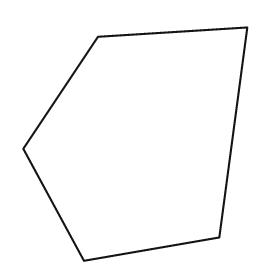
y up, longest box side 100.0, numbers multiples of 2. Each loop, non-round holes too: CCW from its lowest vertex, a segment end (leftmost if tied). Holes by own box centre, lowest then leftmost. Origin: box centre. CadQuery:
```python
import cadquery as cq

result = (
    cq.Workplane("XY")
    .moveTo(-22.0, -50.0)
    .lineTo(36.0, -40.0)
    .lineTo(48.0, 50.0)
    .lineTo(-16.0, 46.0)
    .lineTo(-48.0, -2.0)
    .close()
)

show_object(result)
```